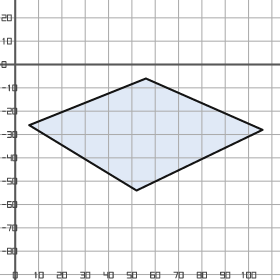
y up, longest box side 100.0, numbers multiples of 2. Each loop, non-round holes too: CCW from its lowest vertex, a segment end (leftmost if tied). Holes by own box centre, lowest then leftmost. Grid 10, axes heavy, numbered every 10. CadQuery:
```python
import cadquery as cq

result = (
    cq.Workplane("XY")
    .moveTo(52.0, -54.0)
    .lineTo(106.0, -28.0)
    .lineTo(56.0, -6.0)
    .lineTo(6.0, -26.0)
    .close()
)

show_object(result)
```